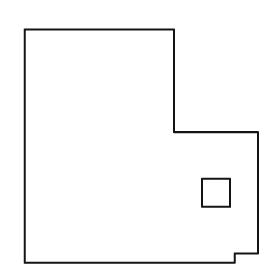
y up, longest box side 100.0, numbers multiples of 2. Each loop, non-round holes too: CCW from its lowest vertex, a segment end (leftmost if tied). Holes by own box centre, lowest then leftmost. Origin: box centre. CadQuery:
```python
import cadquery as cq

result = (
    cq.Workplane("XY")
    .moveTo(-50.0, -50.0)
    .lineTo(40.0, -50.0)
    .lineTo(40.0, -46.0)
    .lineTo(50.0, -46.0)
    .lineTo(50.0, 6.0)
    .lineTo(14.0, 6.0)
    .lineTo(14.0, 50.0)
    .lineTo(-50.0, 50.0)
    .close()
    .moveTo(26.0, -26.0)
    .lineTo(38.0, -26.0)
    .lineTo(38.0, -14.0)
    .lineTo(26.0, -14.0)
    .close()
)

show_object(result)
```